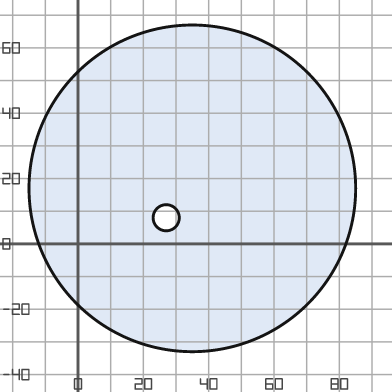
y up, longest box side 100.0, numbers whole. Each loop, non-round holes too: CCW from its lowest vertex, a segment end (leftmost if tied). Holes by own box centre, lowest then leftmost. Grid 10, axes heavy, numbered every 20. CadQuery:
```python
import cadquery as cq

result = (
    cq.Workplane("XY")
    .moveTo(35.0, 17.0)
    .circle(50.0)
    .moveTo(27.0, 8.0)
    .circle(4.0)
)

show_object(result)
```